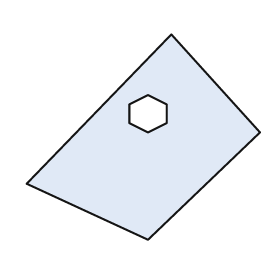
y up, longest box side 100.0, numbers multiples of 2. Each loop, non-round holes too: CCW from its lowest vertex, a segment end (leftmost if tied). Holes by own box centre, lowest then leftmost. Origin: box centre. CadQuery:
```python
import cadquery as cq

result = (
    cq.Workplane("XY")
    .moveTo(2.0, -44.0)
    .lineTo(50.0, 2.0)
    .lineTo(12.0, 44.0)
    .lineTo(-50.0, -20.0)
    .close()
    .moveTo(2.0, 2.0)
    .lineTo(10.0, 6.0)
    .lineTo(10.0, 14.0)
    .lineTo(2.0, 18.0)
    .lineTo(-6.0, 14.0)
    .lineTo(-6.0, 6.0)
    .close()
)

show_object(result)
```